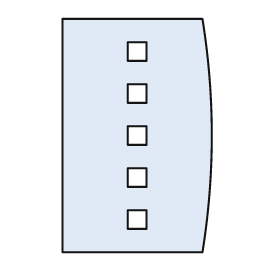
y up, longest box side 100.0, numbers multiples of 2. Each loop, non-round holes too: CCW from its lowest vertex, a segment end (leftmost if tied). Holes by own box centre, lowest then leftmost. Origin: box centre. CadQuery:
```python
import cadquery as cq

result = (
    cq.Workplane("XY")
    .moveTo(-32.0, -50.0)
    .lineTo(28.0, -50.0)
    .threePointArc((32.0, 0.0), (28.0, 50.0))
    .lineTo(-32.0, 50.0)
    .close()
    .moveTo(-4.0, -40.0)
    .lineTo(4.0, -40.0)
    .lineTo(4.0, -32.0)
    .lineTo(-4.0, -32.0)
    .close()
    .moveTo(-4.0, -22.0)
    .lineTo(4.0, -22.0)
    .lineTo(4.0, -14.0)
    .lineTo(-4.0, -14.0)
    .close()
    .moveTo(-4.0, -4.0)
    .lineTo(4.0, -4.0)
    .lineTo(4.0, 4.0)
    .lineTo(-4.0, 4.0)
    .close()
    .moveTo(-4.0, 14.0)
    .lineTo(4.0, 14.0)
    .lineTo(4.0, 22.0)
    .lineTo(-4.0, 22.0)
    .close()
    .moveTo(-4.0, 32.0)
    .lineTo(4.0, 32.0)
    .lineTo(4.0, 40.0)
    .lineTo(-4.0, 40.0)
    .close()
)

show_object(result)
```